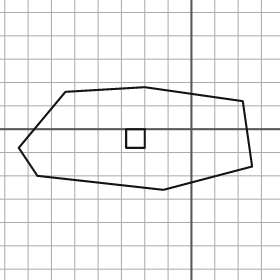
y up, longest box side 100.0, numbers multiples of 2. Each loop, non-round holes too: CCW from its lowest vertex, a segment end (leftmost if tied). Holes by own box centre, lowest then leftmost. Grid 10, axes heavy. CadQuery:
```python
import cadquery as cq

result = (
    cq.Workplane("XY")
    .moveTo(-12.0, -26.0)
    .lineTo(26.0, -16.0)
    .lineTo(22.0, 12.0)
    .lineTo(-20.0, 18.0)
    .lineTo(-54.0, 16.0)
    .lineTo(-74.0, -8.0)
    .lineTo(-66.0, -20.0)
    .close()
    .moveTo(-28.0, -8.0)
    .lineTo(-20.0, -8.0)
    .lineTo(-20.0, 0.0)
    .lineTo(-28.0, 0.0)
    .close()
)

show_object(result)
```